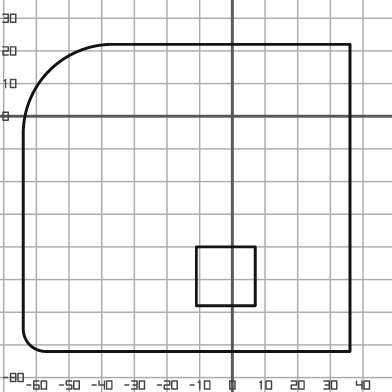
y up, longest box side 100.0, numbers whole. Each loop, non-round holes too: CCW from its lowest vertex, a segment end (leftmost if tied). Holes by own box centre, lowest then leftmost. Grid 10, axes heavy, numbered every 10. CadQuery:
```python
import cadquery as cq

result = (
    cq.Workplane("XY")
    .moveTo(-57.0, -72.0)
    .lineTo(36.0, -72.0)
    .lineTo(36.0, 22.0)
    .lineTo(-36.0, 22.0)
    .threePointArc((-56.0, 14.0), (-64.0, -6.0))
    .lineTo(-64.0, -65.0)
    .threePointArc((-62.0, -70.0), (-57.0, -72.0))
    .close()
    .moveTo(-11.0, -58.0)
    .lineTo(7.0, -58.0)
    .lineTo(7.0, -40.0)
    .lineTo(-11.0, -40.0)
    .close()
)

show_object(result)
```